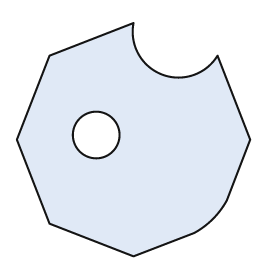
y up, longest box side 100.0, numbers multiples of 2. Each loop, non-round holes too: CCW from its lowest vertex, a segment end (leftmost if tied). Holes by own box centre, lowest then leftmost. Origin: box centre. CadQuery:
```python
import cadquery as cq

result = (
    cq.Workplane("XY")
    .moveTo(0.0, -50.0)
    .lineTo(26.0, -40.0)
    .threePointArc((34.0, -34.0), (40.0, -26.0))
    .lineTo(50.0, 0.0)
    .lineTo(36.0, 36.0)
    .threePointArc((12.0, 28.0), (0.0, 50.0))
    .lineTo(-36.0, 36.0)
    .lineTo(-50.0, 0.0)
    .lineTo(-36.0, -36.0)
    .close()
    .moveTo(-16.0, 2.0)
    .circle(10.0)
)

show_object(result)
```